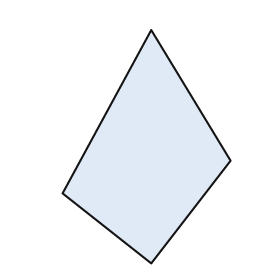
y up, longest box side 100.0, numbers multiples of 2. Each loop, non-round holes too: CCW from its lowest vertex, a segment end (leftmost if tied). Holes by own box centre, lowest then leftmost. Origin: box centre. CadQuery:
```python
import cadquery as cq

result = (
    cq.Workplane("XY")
    .moveTo(2.0, -50.0)
    .lineTo(36.0, -6.0)
    .lineTo(2.0, 50.0)
    .lineTo(-36.0, -20.0)
    .close()
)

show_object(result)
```